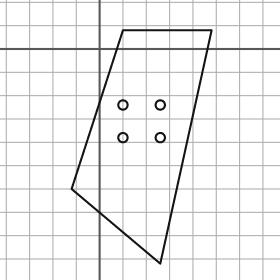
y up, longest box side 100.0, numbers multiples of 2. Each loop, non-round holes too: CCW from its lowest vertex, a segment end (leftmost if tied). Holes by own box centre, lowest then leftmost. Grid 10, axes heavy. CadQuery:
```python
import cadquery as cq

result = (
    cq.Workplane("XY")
    .moveTo(26.0, -92.0)
    .lineTo(48.0, 8.0)
    .lineTo(10.0, 8.0)
    .lineTo(-12.0, -60.0)
    .close()
    .moveTo(10.0, -38.0)
    .circle(2.0)
    .moveTo(26.0, -38.0)
    .circle(2.0)
    .moveTo(10.0, -24.0)
    .circle(2.0)
    .moveTo(26.0, -24.0)
    .circle(2.0)
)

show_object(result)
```